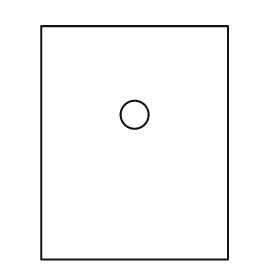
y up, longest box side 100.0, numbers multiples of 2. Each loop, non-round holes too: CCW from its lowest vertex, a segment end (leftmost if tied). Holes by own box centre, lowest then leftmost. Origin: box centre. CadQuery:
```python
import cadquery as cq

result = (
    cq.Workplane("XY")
    .moveTo(-40.0, -50.0)
    .lineTo(40.0, -50.0)
    .lineTo(40.0, 50.0)
    .lineTo(-40.0, 50.0)
    .close()
    .moveTo(0.0, 12.0)
    .circle(6.0)
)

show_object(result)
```